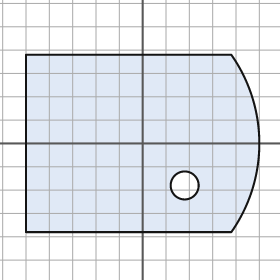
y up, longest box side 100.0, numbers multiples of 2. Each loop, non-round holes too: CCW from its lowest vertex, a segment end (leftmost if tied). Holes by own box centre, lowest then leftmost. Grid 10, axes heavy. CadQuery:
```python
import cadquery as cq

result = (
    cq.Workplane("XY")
    .moveTo(-50.0, -38.0)
    .lineTo(38.0, -38.0)
    .threePointArc((50.0, 0.0), (38.0, 38.0))
    .lineTo(-50.0, 38.0)
    .close()
    .moveTo(18.0, -18.0)
    .circle(6.0)
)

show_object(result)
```